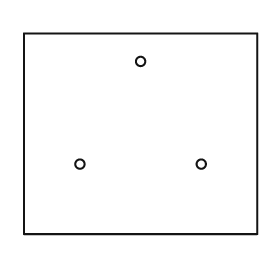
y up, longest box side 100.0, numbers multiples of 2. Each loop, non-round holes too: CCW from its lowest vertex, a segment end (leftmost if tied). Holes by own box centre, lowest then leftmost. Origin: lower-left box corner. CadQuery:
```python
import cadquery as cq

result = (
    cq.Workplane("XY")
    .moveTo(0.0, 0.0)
    .lineTo(100.0, 0.0)
    .lineTo(100.0, 86.0)
    .lineTo(0.0, 86.0)
    .close()
    .moveTo(24.0, 30.0)
    .circle(2.0)
    .moveTo(76.0, 30.0)
    .circle(2.0)
    .moveTo(50.0, 74.0)
    .circle(2.0)
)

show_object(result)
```